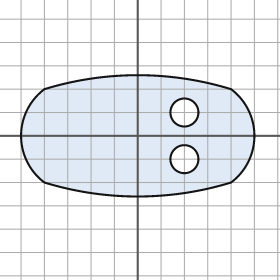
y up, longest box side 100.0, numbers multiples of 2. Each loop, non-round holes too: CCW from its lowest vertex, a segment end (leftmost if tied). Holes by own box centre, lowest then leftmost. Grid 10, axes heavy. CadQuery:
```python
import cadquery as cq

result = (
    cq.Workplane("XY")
    .moveTo(-40.0, -20.0)
    .threePointArc((0.0, -26.0), (40.0, -20.0))
    .threePointArc((50.0, 0.0), (40.0, 20.0))
    .threePointArc((0.0, 26.0), (-40.0, 20.0))
    .threePointArc((-50.0, 0.0), (-40.0, -20.0))
    .close()
    .moveTo(20.0, -10.0)
    .circle(6.0)
    .moveTo(20.0, 10.0)
    .circle(6.0)
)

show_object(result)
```